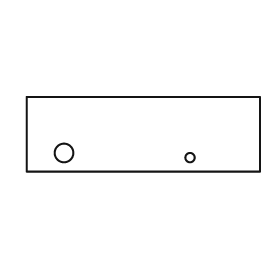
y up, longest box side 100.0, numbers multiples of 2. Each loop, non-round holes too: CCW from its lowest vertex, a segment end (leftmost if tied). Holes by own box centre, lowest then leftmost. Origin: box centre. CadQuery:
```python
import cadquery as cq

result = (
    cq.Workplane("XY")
    .moveTo(-50.0, -16.0)
    .lineTo(50.0, -16.0)
    .lineTo(50.0, 16.0)
    .lineTo(-50.0, 16.0)
    .close()
    .moveTo(20.0, -10.0)
    .circle(2.0)
    .moveTo(-34.0, -8.0)
    .circle(4.0)
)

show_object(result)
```